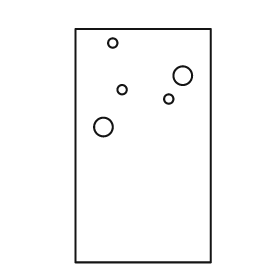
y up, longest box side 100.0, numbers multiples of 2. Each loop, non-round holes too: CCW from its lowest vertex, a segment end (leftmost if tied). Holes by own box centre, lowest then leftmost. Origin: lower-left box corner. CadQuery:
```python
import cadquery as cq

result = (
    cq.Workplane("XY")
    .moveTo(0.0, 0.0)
    .lineTo(58.0, 0.0)
    .lineTo(58.0, 100.0)
    .lineTo(0.0, 100.0)
    .close()
    .moveTo(12.0, 58.0)
    .circle(4.0)
    .moveTo(40.0, 70.0)
    .circle(2.0)
    .moveTo(20.0, 74.0)
    .circle(2.0)
    .moveTo(46.0, 80.0)
    .circle(4.0)
    .moveTo(16.0, 94.0)
    .circle(2.0)
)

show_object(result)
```